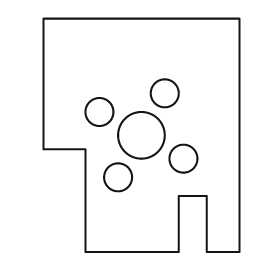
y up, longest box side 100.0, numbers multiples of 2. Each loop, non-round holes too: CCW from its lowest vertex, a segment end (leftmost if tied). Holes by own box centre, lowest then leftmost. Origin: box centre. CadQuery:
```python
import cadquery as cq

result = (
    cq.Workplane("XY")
    .moveTo(-24.0, -50.0)
    .lineTo(16.0, -50.0)
    .lineTo(16.0, -26.0)
    .lineTo(28.0, -26.0)
    .lineTo(28.0, -50.0)
    .lineTo(42.0, -50.0)
    .lineTo(42.0, 50.0)
    .lineTo(-42.0, 50.0)
    .lineTo(-42.0, -6.0)
    .lineTo(-24.0, -6.0)
    .close()
    .moveTo(-10.0, -18.0)
    .circle(6.0)
    .moveTo(18.0, -10.0)
    .circle(6.0)
    .moveTo(0.0, 0.0)
    .circle(10.0)
    .moveTo(-18.0, 10.0)
    .circle(6.0)
    .moveTo(10.0, 18.0)
    .circle(6.0)
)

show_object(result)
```